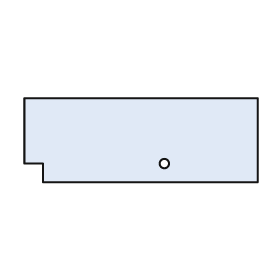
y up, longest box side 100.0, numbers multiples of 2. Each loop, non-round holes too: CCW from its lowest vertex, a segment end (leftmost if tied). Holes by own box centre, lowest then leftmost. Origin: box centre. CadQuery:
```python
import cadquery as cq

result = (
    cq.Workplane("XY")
    .moveTo(-42.0, -18.0)
    .lineTo(50.0, -18.0)
    .lineTo(50.0, 18.0)
    .lineTo(-50.0, 18.0)
    .lineTo(-50.0, -10.0)
    .lineTo(-42.0, -10.0)
    .close()
    .moveTo(10.0, -10.0)
    .circle(2.0)
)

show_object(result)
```